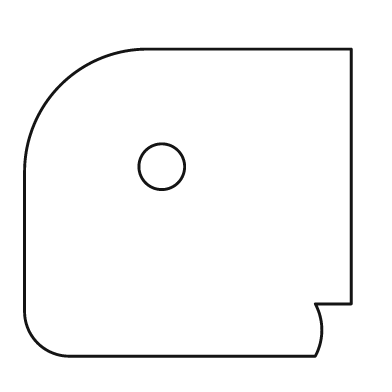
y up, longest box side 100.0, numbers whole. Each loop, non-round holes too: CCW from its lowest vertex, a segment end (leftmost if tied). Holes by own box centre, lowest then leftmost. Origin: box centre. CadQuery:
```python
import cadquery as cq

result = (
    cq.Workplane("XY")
    .moveTo(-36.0, -47.0)
    .lineTo(39.0, -47.0)
    .threePointArc((41.0, -39.0), (39.0, -31.0))
    .lineTo(50.0, -31.0)
    .lineTo(50.0, 47.0)
    .lineTo(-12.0, 47.0)
    .threePointArc((-39.0, 36.0), (-50.0, 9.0))
    .lineTo(-50.0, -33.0)
    .threePointArc((-46.0, -43.0), (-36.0, -47.0))
    .close()
    .moveTo(-8.0, 11.0)
    .circle(7.0)
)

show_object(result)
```